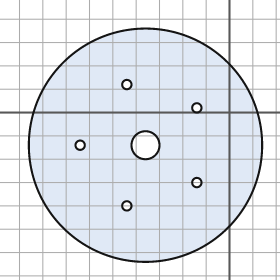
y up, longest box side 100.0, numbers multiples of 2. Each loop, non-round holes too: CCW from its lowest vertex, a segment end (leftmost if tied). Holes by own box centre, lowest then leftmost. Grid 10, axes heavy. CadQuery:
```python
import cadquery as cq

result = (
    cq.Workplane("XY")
    .moveTo(-36.0, -14.0)
    .circle(50.0)
    .moveTo(-44.0, -40.0)
    .circle(2.0)
    .moveTo(-14.0, -30.0)
    .circle(2.0)
    .moveTo(-64.0, -14.0)
    .circle(2.0)
    .moveTo(-36.0, -14.0)
    .circle(6.0)
    .moveTo(-14.0, 2.0)
    .circle(2.0)
    .moveTo(-44.0, 12.0)
    .circle(2.0)
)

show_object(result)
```